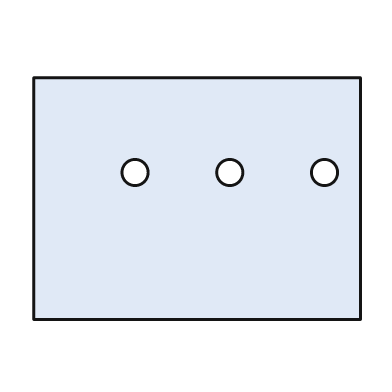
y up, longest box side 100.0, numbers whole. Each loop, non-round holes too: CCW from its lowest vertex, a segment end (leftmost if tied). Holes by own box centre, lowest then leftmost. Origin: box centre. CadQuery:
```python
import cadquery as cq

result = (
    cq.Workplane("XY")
    .moveTo(-50.0, -37.0)
    .lineTo(50.0, -37.0)
    .lineTo(50.0, 37.0)
    .lineTo(-50.0, 37.0)
    .close()
    .moveTo(-19.0, 8.0)
    .circle(4.0)
    .moveTo(10.0, 8.0)
    .circle(4.0)
    .moveTo(39.0, 8.0)
    .circle(4.0)
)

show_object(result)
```